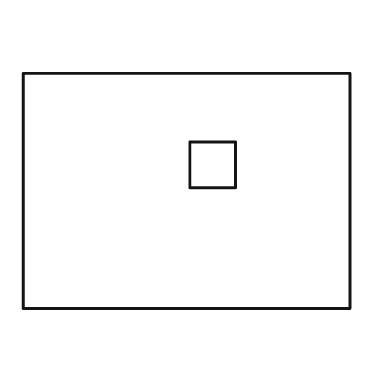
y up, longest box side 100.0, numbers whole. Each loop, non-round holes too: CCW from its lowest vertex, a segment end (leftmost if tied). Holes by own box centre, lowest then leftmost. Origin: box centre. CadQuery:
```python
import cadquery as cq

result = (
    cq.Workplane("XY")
    .moveTo(-50.0, -36.0)
    .lineTo(50.0, -36.0)
    .lineTo(50.0, 36.0)
    .lineTo(-50.0, 36.0)
    .close()
    .moveTo(1.0, 1.0)
    .lineTo(15.0, 1.0)
    .lineTo(15.0, 15.0)
    .lineTo(1.0, 15.0)
    .close()
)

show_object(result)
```